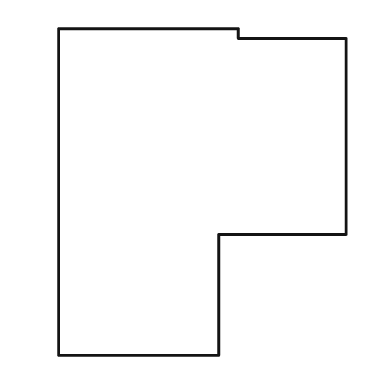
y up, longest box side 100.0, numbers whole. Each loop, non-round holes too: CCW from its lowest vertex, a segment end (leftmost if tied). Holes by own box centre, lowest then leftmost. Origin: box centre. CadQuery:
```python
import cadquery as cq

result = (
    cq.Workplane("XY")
    .moveTo(-44.0, -50.0)
    .lineTo(5.0, -50.0)
    .lineTo(5.0, -13.0)
    .lineTo(44.0, -13.0)
    .lineTo(44.0, 47.0)
    .lineTo(11.0, 47.0)
    .lineTo(11.0, 50.0)
    .lineTo(-44.0, 50.0)
    .close()
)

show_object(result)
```